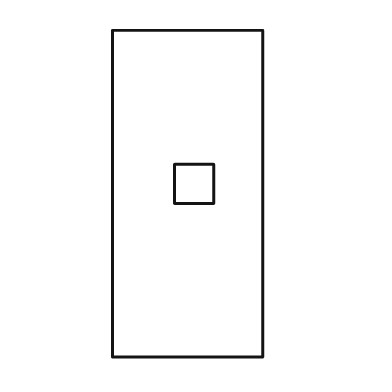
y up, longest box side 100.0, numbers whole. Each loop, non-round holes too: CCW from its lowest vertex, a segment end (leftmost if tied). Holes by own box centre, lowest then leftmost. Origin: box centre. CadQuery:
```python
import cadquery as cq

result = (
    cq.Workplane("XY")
    .moveTo(-23.0, -50.0)
    .lineTo(23.0, -50.0)
    .lineTo(23.0, 50.0)
    .lineTo(-23.0, 50.0)
    .close()
    .moveTo(-4.0, -3.0)
    .lineTo(8.0, -3.0)
    .lineTo(8.0, 9.0)
    .lineTo(-4.0, 9.0)
    .close()
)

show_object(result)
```